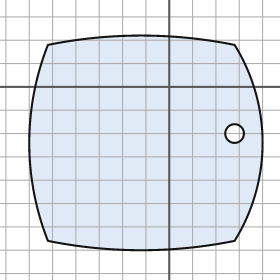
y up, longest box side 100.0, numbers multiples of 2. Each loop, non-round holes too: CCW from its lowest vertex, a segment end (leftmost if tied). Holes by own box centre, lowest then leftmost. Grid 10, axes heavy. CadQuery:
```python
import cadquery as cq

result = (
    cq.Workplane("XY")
    .moveTo(-52.0, -66.0)
    .threePointArc((-12.0, -70.0), (28.0, -66.0))
    .threePointArc((40.0, -24.0), (28.0, 18.0))
    .threePointArc((-12.0, 22.0), (-52.0, 18.0))
    .threePointArc((-60.0, -24.0), (-52.0, -66.0))
    .close()
    .moveTo(28.0, -20.0)
    .circle(4.0)
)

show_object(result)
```